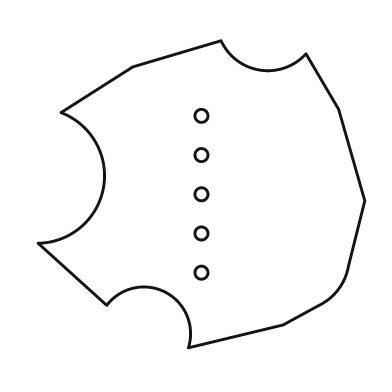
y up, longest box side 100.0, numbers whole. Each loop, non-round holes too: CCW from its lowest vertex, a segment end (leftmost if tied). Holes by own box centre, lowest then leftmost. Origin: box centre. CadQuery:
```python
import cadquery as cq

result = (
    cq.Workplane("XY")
    .moveTo(-4.0, -47.0)
    .lineTo(25.0, -40.0)
    .lineTo(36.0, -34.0)
    .threePointArc((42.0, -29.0), (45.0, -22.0))
    .lineTo(50.0, -2.0)
    .lineTo(42.0, 26.0)
    .lineTo(32.0, 43.0)
    .threePointArc((18.0, 38.0), (6.0, 47.0))
    .lineTo(-21.0, 39.0)
    .lineTo(-43.0, 25.0)
    .threePointArc((-30.0, 2.0), (-50.0, -15.0))
    .lineTo(-29.0, -34.0)
    .threePointArc((-11.0, -30.0), (-4.0, -47.0))
    .close()
    .moveTo(0.0, -24.0)
    .circle(2.0)
    .moveTo(0.0, -12.0)
    .circle(2.0)
    .moveTo(0.0, 0.0)
    .circle(2.0)
    .moveTo(0.0, 12.0)
    .circle(2.0)
    .moveTo(0.0, 24.0)
    .circle(2.0)
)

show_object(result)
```